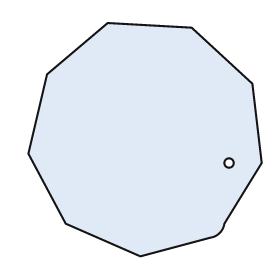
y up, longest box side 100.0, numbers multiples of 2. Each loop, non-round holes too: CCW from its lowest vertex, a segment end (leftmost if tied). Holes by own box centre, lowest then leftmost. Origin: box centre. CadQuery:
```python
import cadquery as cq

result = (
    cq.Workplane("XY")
    .moveTo(-2.0, -50.0)
    .lineTo(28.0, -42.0)
    .threePointArc((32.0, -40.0), (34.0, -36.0))
    .lineTo(50.0, -10.0)
    .lineTo(46.0, 24.0)
    .lineTo(20.0, 48.0)
    .lineTo(-16.0, 50.0)
    .lineTo(-42.0, 28.0)
    .lineTo(-50.0, -6.0)
    .lineTo(-34.0, -36.0)
    .close()
    .moveTo(36.0, -10.0)
    .circle(2.0)
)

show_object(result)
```